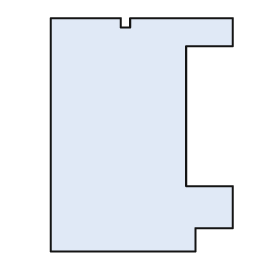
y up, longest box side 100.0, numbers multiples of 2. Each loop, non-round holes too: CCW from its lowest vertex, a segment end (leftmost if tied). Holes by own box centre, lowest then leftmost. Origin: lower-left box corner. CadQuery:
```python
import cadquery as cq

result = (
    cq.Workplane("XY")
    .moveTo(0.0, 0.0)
    .lineTo(62.0, 0.0)
    .lineTo(62.0, 10.0)
    .lineTo(78.0, 10.0)
    .lineTo(78.0, 28.0)
    .lineTo(58.0, 28.0)
    .lineTo(58.0, 88.0)
    .lineTo(78.0, 88.0)
    .lineTo(78.0, 100.0)
    .lineTo(34.0, 100.0)
    .lineTo(34.0, 96.0)
    .lineTo(30.0, 96.0)
    .lineTo(30.0, 100.0)
    .lineTo(0.0, 100.0)
    .close()
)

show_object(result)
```